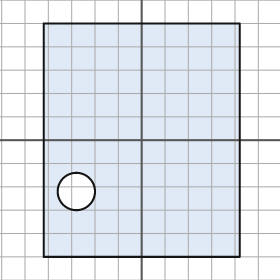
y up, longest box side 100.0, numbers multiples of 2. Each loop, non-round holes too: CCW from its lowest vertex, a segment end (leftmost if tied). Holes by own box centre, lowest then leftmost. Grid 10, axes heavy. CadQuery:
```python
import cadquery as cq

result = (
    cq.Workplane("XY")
    .moveTo(-42.0, -50.0)
    .lineTo(42.0, -50.0)
    .lineTo(42.0, 50.0)
    .lineTo(-42.0, 50.0)
    .close()
    .moveTo(-28.0, -22.0)
    .circle(8.0)
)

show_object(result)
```